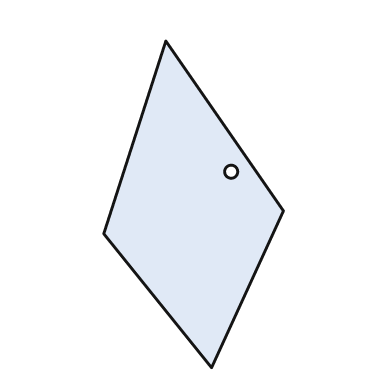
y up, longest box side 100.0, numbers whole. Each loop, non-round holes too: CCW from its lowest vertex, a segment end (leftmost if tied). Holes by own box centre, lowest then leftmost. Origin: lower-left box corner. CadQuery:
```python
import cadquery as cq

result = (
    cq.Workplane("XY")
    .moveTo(33.0, 0.0)
    .lineTo(55.0, 48.0)
    .lineTo(19.0, 100.0)
    .lineTo(0.0, 41.0)
    .close()
    .moveTo(39.0, 60.0)
    .circle(2.0)
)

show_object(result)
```